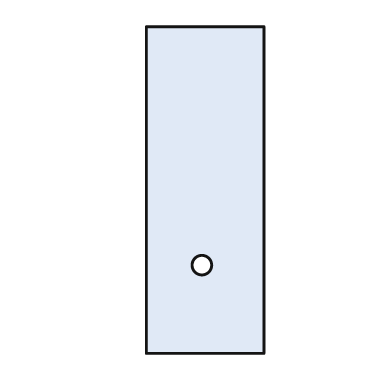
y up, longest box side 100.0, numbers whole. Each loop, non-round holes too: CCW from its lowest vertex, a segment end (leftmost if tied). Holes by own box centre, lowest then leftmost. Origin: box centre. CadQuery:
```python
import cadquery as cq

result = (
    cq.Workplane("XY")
    .moveTo(-18.0, -50.0)
    .lineTo(18.0, -50.0)
    .lineTo(18.0, 50.0)
    .lineTo(-18.0, 50.0)
    .close()
    .moveTo(-1.0, -23.0)
    .circle(3.0)
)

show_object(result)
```